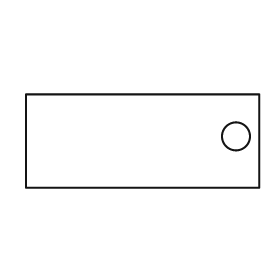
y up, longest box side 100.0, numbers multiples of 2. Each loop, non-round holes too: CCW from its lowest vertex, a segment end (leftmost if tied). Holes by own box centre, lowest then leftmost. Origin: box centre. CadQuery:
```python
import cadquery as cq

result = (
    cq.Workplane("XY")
    .moveTo(-50.0, -20.0)
    .lineTo(50.0, -20.0)
    .lineTo(50.0, 20.0)
    .lineTo(-50.0, 20.0)
    .close()
    .moveTo(40.0, 2.0)
    .circle(6.0)
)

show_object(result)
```